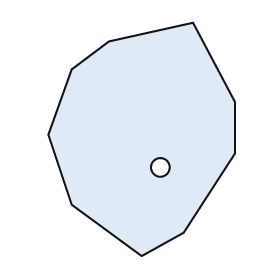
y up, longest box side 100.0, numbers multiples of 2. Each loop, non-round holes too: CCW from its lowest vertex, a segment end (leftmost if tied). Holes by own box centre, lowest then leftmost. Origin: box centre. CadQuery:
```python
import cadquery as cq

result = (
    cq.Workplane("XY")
    .moveTo(0.0, -50.0)
    .lineTo(18.0, -40.0)
    .lineTo(40.0, -6.0)
    .lineTo(40.0, 16.0)
    .lineTo(22.0, 50.0)
    .lineTo(-14.0, 42.0)
    .lineTo(-30.0, 30.0)
    .lineTo(-40.0, 2.0)
    .lineTo(-30.0, -28.0)
    .close()
    .moveTo(8.0, -12.0)
    .circle(4.0)
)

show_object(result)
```